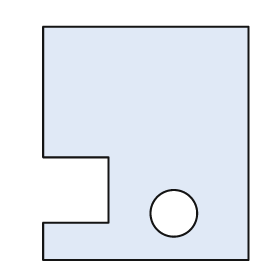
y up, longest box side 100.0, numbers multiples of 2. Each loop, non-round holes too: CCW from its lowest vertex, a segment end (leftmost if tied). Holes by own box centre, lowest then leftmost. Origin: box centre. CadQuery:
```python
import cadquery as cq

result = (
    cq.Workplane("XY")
    .moveTo(-44.0, -50.0)
    .lineTo(44.0, -50.0)
    .lineTo(44.0, 50.0)
    .lineTo(-44.0, 50.0)
    .lineTo(-44.0, -6.0)
    .lineTo(-16.0, -6.0)
    .lineTo(-16.0, -34.0)
    .lineTo(-44.0, -34.0)
    .close()
    .moveTo(12.0, -30.0)
    .circle(10.0)
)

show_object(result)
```